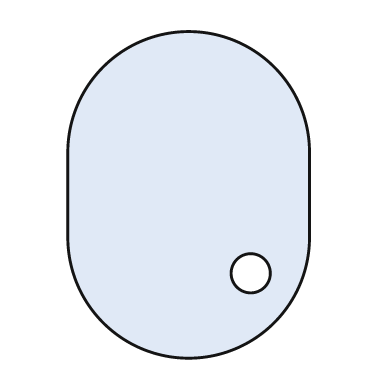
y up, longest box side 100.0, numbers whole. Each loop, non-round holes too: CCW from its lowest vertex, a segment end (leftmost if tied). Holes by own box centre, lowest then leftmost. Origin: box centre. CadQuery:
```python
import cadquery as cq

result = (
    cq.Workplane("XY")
    .moveTo(-37.0, -13.0)
    .threePointArc((0.0, -50.0), (37.0, -13.0))
    .lineTo(37.0, 13.0)
    .threePointArc((0.0, 50.0), (-37.0, 13.0))
    .close()
    .moveTo(19.0, -24.0)
    .circle(6.0)
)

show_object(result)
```